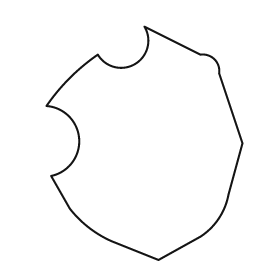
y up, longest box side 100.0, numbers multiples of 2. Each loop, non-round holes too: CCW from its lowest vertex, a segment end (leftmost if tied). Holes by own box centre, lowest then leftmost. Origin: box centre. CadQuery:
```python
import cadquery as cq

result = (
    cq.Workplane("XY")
    .moveTo(6.0, -50.0)
    .lineTo(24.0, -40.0)
    .threePointArc((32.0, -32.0), (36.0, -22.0))
    .lineTo(42.0, 0.0)
    .lineTo(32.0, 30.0)
    .threePointArc((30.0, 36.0), (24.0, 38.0))
    .lineTo(0.0, 50.0)
    .threePointArc((-4.0, 34.0), (-20.0, 38.0))
    .threePointArc((-32.0, 28.0), (-42.0, 16.0))
    .threePointArc((-28.0, 2.0), (-40.0, -14.0))
    .lineTo(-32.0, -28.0)
    .threePointArc((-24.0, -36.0), (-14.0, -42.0))
    .close()
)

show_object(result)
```